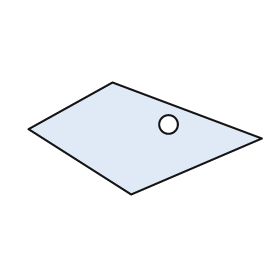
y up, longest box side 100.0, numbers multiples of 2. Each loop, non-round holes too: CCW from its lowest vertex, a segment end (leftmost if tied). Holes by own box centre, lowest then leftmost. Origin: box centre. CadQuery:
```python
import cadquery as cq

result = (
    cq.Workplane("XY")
    .moveTo(-6.0, -24.0)
    .lineTo(50.0, 0.0)
    .lineTo(-14.0, 24.0)
    .lineTo(-50.0, 4.0)
    .close()
    .moveTo(10.0, 6.0)
    .circle(4.0)
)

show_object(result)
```